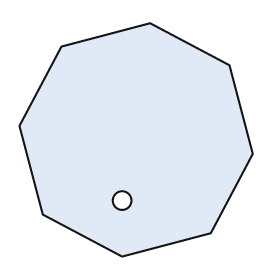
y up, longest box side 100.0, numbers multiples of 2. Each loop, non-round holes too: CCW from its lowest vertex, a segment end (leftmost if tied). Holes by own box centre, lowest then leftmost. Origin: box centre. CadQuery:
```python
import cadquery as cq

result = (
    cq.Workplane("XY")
    .moveTo(-6.0, -50.0)
    .lineTo(32.0, -40.0)
    .lineTo(50.0, -6.0)
    .lineTo(40.0, 32.0)
    .lineTo(6.0, 50.0)
    .lineTo(-32.0, 40.0)
    .lineTo(-50.0, 6.0)
    .lineTo(-40.0, -32.0)
    .close()
    .moveTo(-6.0, -26.0)
    .circle(4.0)
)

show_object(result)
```